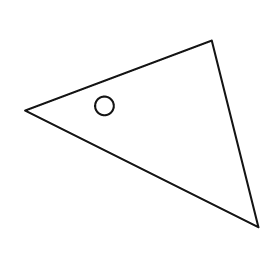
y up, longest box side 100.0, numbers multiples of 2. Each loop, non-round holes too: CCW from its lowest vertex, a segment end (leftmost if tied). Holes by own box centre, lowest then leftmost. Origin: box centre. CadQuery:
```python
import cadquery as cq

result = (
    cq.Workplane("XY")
    .moveTo(50.0, -40.0)
    .lineTo(30.0, 40.0)
    .lineTo(-50.0, 10.0)
    .close()
    .moveTo(-16.0, 12.0)
    .circle(4.0)
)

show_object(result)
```